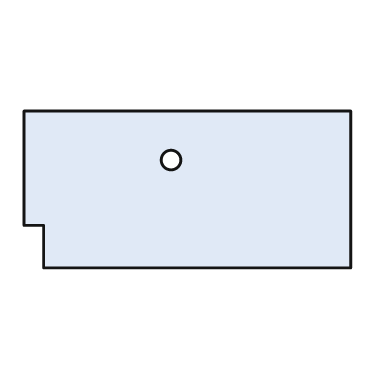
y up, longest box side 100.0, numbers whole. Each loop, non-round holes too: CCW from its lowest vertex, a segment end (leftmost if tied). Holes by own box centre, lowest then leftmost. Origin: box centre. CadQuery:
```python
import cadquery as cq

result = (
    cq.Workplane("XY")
    .moveTo(-44.0, -24.0)
    .lineTo(50.0, -24.0)
    .lineTo(50.0, 24.0)
    .lineTo(-50.0, 24.0)
    .lineTo(-50.0, -11.0)
    .lineTo(-44.0, -11.0)
    .close()
    .moveTo(-5.0, 9.0)
    .circle(3.0)
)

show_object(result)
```